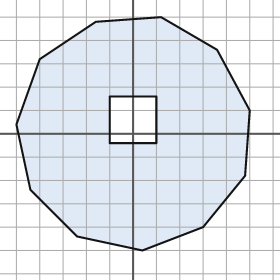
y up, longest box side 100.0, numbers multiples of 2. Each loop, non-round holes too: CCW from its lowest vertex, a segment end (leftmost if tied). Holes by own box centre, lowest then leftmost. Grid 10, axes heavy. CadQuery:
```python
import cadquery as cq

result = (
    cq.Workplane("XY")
    .moveTo(4.0, -50.0)
    .lineTo(30.0, -40.0)
    .lineTo(48.0, -18.0)
    .lineTo(50.0, 10.0)
    .lineTo(36.0, 36.0)
    .lineTo(12.0, 50.0)
    .lineTo(-16.0, 48.0)
    .lineTo(-40.0, 32.0)
    .lineTo(-50.0, 4.0)
    .lineTo(-44.0, -24.0)
    .lineTo(-24.0, -44.0)
    .close()
    .moveTo(-10.0, -4.0)
    .lineTo(10.0, -4.0)
    .lineTo(10.0, 16.0)
    .lineTo(-10.0, 16.0)
    .close()
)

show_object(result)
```